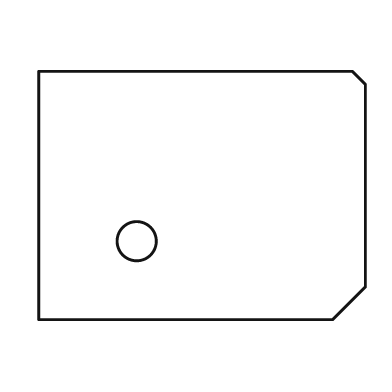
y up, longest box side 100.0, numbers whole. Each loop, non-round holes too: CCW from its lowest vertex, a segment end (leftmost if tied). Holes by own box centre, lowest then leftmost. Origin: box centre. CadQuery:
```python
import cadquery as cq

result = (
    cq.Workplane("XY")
    .moveTo(-50.0, -38.0)
    .lineTo(40.0, -38.0)
    .lineTo(50.0, -28.0)
    .lineTo(50.0, 34.0)
    .lineTo(46.0, 38.0)
    .lineTo(-50.0, 38.0)
    .close()
    .moveTo(-20.0, -14.0)
    .circle(6.0)
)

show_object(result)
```